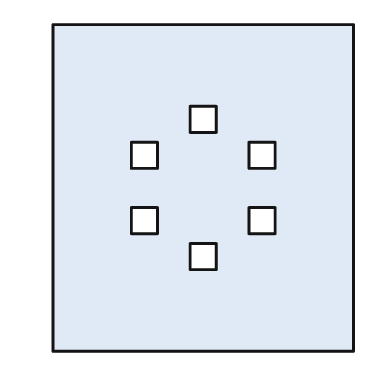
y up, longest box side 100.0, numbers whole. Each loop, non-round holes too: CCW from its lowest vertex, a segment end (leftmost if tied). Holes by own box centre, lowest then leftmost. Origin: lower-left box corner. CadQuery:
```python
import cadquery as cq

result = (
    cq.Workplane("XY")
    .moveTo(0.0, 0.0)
    .lineTo(92.0, 0.0)
    .lineTo(92.0, 100.0)
    .lineTo(0.0, 100.0)
    .close()
    .moveTo(42.0, 25.0)
    .lineTo(50.0, 25.0)
    .lineTo(50.0, 33.0)
    .lineTo(42.0, 33.0)
    .close()
    .moveTo(24.0, 36.0)
    .lineTo(32.0, 36.0)
    .lineTo(32.0, 44.0)
    .lineTo(24.0, 44.0)
    .close()
    .moveTo(60.0, 36.0)
    .lineTo(68.0, 36.0)
    .lineTo(68.0, 44.0)
    .lineTo(60.0, 44.0)
    .close()
    .moveTo(24.0, 56.0)
    .lineTo(32.0, 56.0)
    .lineTo(32.0, 64.0)
    .lineTo(24.0, 64.0)
    .close()
    .moveTo(60.0, 56.0)
    .lineTo(68.0, 56.0)
    .lineTo(68.0, 64.0)
    .lineTo(60.0, 64.0)
    .close()
    .moveTo(42.0, 67.0)
    .lineTo(50.0, 67.0)
    .lineTo(50.0, 75.0)
    .lineTo(42.0, 75.0)
    .close()
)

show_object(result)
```